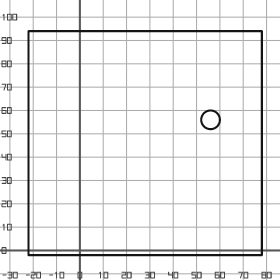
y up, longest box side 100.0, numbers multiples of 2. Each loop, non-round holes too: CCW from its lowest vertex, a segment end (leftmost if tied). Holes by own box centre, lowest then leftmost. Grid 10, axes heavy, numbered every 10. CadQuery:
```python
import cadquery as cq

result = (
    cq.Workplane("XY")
    .moveTo(-22.0, -2.0)
    .lineTo(78.0, -2.0)
    .lineTo(78.0, 94.0)
    .lineTo(-22.0, 94.0)
    .close()
    .moveTo(56.0, 56.0)
    .circle(4.0)
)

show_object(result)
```